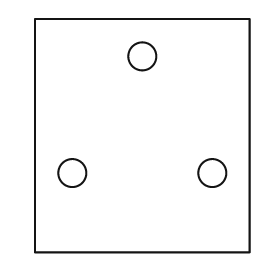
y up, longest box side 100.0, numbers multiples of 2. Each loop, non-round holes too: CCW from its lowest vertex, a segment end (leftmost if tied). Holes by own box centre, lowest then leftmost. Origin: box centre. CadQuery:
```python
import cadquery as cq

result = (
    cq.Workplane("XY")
    .moveTo(-46.0, -50.0)
    .lineTo(46.0, -50.0)
    .lineTo(46.0, 50.0)
    .lineTo(-46.0, 50.0)
    .close()
    .moveTo(-30.0, -16.0)
    .circle(6.0)
    .moveTo(30.0, -16.0)
    .circle(6.0)
    .moveTo(0.0, 34.0)
    .circle(6.0)
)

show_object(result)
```